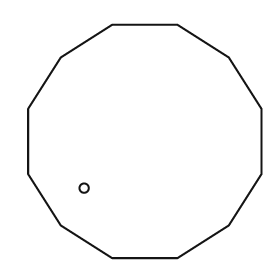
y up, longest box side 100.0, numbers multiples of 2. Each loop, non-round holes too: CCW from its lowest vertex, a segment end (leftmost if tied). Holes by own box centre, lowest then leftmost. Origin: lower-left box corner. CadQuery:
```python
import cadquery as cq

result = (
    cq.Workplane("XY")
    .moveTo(36.0, 0.0)
    .lineTo(64.0, 0.0)
    .lineTo(86.0, 14.0)
    .lineTo(100.0, 36.0)
    .lineTo(100.0, 64.0)
    .lineTo(86.0, 86.0)
    .lineTo(64.0, 100.0)
    .lineTo(36.0, 100.0)
    .lineTo(14.0, 86.0)
    .lineTo(0.0, 64.0)
    .lineTo(0.0, 36.0)
    .lineTo(14.0, 14.0)
    .close()
    .moveTo(24.0, 30.0)
    .circle(2.0)
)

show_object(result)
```